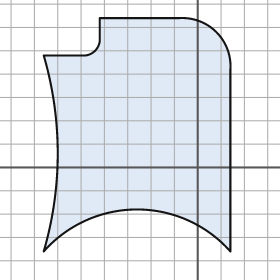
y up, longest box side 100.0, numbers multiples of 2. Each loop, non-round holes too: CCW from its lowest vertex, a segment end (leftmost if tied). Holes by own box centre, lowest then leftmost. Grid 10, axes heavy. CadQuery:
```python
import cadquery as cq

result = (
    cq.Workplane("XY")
    .moveTo(-66.0, -36.0)
    .threePointArc((-26.0, -18.0), (14.0, -36.0))
    .lineTo(14.0, 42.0)
    .threePointArc((8.0, 58.0), (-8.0, 64.0))
    .lineTo(-42.0, 64.0)
    .lineTo(-42.0, 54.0)
    .threePointArc((-44.0, 50.0), (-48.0, 48.0))
    .lineTo(-66.0, 48.0)
    .threePointArc((-60.0, 6.0), (-66.0, -36.0))
    .close()
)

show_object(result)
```